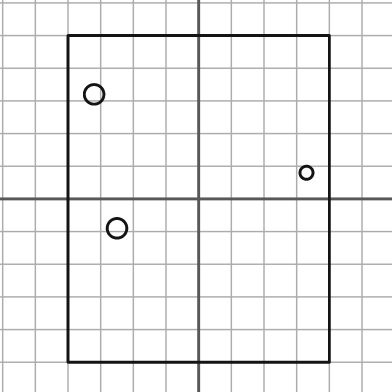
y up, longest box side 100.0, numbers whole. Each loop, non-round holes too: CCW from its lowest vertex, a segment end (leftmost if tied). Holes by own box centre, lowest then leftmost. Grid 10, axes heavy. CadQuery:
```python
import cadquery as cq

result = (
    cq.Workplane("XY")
    .moveTo(-40.0, -50.0)
    .lineTo(40.0, -50.0)
    .lineTo(40.0, 50.0)
    .lineTo(-40.0, 50.0)
    .close()
    .moveTo(-25.0, -9.0)
    .circle(3.0)
    .moveTo(33.0, 8.0)
    .circle(2.0)
    .moveTo(-32.0, 32.0)
    .circle(3.0)
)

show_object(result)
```